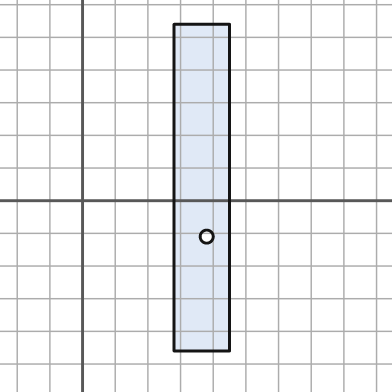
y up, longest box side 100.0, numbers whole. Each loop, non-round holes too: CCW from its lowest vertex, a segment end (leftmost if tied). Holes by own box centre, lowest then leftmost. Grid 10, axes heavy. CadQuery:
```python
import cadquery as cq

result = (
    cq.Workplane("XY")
    .moveTo(28.0, -46.0)
    .lineTo(45.0, -46.0)
    .lineTo(45.0, 54.0)
    .lineTo(28.0, 54.0)
    .close()
    .moveTo(38.0, -11.0)
    .circle(2.0)
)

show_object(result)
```